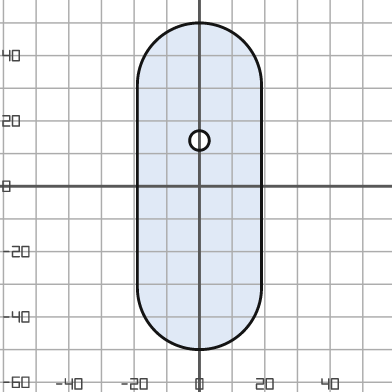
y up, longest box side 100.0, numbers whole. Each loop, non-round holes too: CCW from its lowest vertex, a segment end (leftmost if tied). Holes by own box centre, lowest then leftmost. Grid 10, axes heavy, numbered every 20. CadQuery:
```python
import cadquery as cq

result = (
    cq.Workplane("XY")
    .moveTo(-19.0, -31.0)
    .threePointArc((0.0, -50.0), (19.0, -31.0))
    .lineTo(19.0, 31.0)
    .threePointArc((0.0, 50.0), (-19.0, 31.0))
    .close()
    .moveTo(0.0, 14.0)
    .circle(3.0)
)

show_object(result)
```